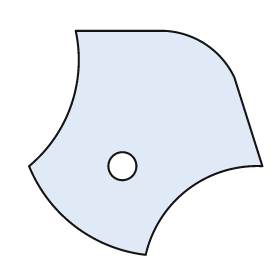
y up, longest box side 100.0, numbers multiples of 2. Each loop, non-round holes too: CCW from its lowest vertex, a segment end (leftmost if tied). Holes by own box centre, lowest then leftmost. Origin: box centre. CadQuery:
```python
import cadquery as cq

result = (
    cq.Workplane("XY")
    .moveTo(0.0, -48.0)
    .threePointArc((18.0, -20.0), (50.0, -10.0))
    .lineTo(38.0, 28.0)
    .threePointArc((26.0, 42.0), (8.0, 48.0))
    .lineTo(-30.0, 48.0)
    .threePointArc((-32.0, 16.0), (-50.0, -10.0))
    .threePointArc((-30.0, -36.0), (0.0, -48.0))
    .close()
    .moveTo(-10.0, -10.0)
    .circle(6.0)
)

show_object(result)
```